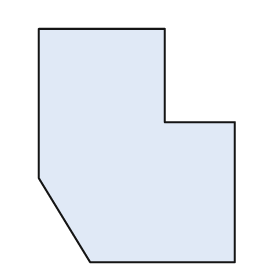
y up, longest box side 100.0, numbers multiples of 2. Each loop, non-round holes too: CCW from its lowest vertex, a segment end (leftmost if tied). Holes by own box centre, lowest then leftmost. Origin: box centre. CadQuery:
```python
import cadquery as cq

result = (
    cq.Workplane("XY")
    .moveTo(-20.0, -50.0)
    .lineTo(42.0, -50.0)
    .lineTo(42.0, 10.0)
    .lineTo(12.0, 10.0)
    .lineTo(12.0, 50.0)
    .lineTo(-42.0, 50.0)
    .lineTo(-42.0, -14.0)
    .close()
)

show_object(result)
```